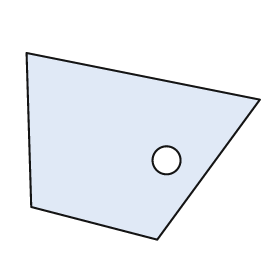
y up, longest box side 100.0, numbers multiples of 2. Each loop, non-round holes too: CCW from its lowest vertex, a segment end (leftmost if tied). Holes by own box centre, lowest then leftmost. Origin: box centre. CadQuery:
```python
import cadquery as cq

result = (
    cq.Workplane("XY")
    .moveTo(6.0, -40.0)
    .lineTo(50.0, 20.0)
    .lineTo(-50.0, 40.0)
    .lineTo(-48.0, -26.0)
    .close()
    .moveTo(10.0, -6.0)
    .circle(6.0)
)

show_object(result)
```